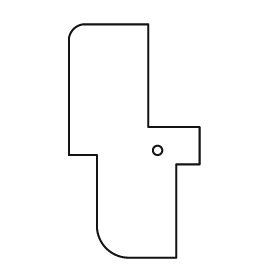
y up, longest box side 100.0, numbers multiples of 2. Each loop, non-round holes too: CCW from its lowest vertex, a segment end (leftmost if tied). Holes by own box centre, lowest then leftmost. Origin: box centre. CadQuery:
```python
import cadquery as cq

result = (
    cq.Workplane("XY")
    .moveTo(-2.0, -50.0)
    .lineTo(18.0, -50.0)
    .lineTo(18.0, -10.0)
    .lineTo(28.0, -10.0)
    .lineTo(28.0, 6.0)
    .lineTo(6.0, 6.0)
    .lineTo(6.0, 50.0)
    .lineTo(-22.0, 50.0)
    .threePointArc((-26.0, 48.0), (-28.0, 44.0))
    .lineTo(-28.0, -6.0)
    .lineTo(-16.0, -6.0)
    .lineTo(-16.0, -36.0)
    .threePointArc((-12.0, -46.0), (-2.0, -50.0))
    .close()
    .moveTo(10.0, -4.0)
    .circle(2.0)
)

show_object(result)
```